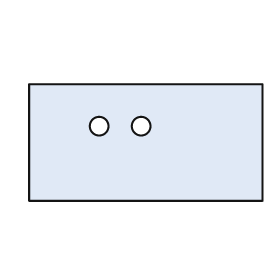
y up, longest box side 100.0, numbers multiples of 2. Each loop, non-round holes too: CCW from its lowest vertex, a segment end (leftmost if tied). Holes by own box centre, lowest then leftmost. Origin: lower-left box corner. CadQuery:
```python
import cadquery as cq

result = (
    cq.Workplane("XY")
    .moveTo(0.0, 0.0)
    .lineTo(100.0, 0.0)
    .lineTo(100.0, 50.0)
    .lineTo(0.0, 50.0)
    .close()
    .moveTo(30.0, 32.0)
    .circle(4.0)
    .moveTo(48.0, 32.0)
    .circle(4.0)
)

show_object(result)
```